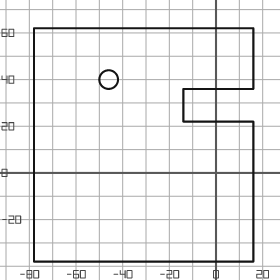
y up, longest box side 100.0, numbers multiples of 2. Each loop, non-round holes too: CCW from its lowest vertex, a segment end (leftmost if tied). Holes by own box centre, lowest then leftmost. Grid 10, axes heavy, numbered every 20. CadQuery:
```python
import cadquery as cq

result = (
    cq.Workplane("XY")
    .moveTo(-78.0, -38.0)
    .lineTo(16.0, -38.0)
    .lineTo(16.0, 22.0)
    .lineTo(-14.0, 22.0)
    .lineTo(-14.0, 36.0)
    .lineTo(16.0, 36.0)
    .lineTo(16.0, 62.0)
    .lineTo(-78.0, 62.0)
    .close()
    .moveTo(-46.0, 40.0)
    .circle(4.0)
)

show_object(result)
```